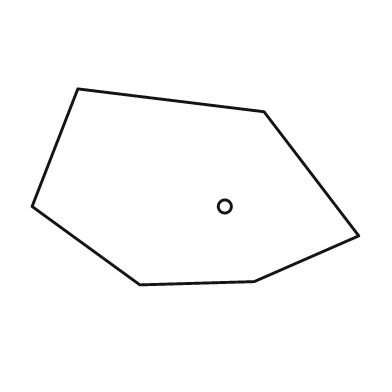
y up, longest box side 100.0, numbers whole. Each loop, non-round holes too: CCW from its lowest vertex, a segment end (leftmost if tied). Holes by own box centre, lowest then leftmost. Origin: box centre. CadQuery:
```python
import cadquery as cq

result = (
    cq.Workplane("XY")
    .moveTo(-17.0, -30.0)
    .lineTo(18.0, -29.0)
    .lineTo(50.0, -15.0)
    .lineTo(21.0, 23.0)
    .lineTo(-36.0, 30.0)
    .lineTo(-50.0, -6.0)
    .close()
    .moveTo(9.0, -6.0)
    .circle(2.0)
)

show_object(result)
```